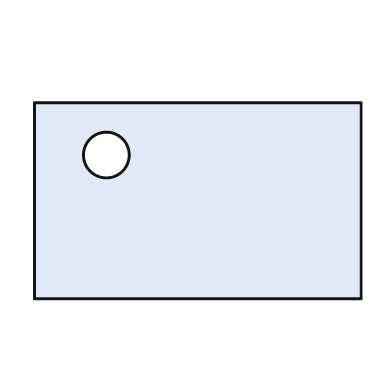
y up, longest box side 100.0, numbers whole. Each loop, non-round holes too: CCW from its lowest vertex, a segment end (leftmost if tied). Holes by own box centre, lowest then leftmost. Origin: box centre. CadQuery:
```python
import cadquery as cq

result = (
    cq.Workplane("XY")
    .moveTo(-50.0, -30.0)
    .lineTo(50.0, -30.0)
    .lineTo(50.0, 30.0)
    .lineTo(-50.0, 30.0)
    .close()
    .moveTo(-28.0, 14.0)
    .circle(7.0)
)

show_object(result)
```